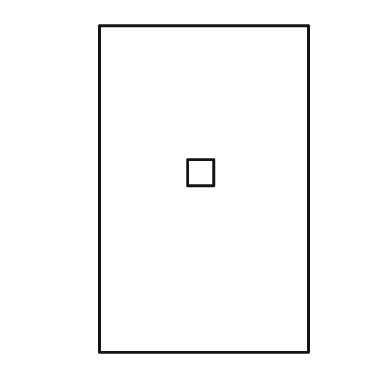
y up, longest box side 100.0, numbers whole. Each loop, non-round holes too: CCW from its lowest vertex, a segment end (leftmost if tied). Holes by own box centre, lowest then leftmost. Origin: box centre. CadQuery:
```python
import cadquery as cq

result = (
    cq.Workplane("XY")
    .moveTo(-32.0, -50.0)
    .lineTo(32.0, -50.0)
    .lineTo(32.0, 50.0)
    .lineTo(-32.0, 50.0)
    .close()
    .moveTo(-5.0, 1.0)
    .lineTo(3.0, 1.0)
    .lineTo(3.0, 9.0)
    .lineTo(-5.0, 9.0)
    .close()
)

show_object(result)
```